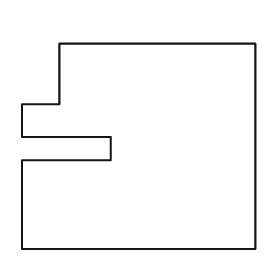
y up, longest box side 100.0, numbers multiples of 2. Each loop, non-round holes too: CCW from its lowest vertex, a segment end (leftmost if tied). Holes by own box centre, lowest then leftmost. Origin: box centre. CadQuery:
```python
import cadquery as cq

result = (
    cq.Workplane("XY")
    .moveTo(-50.0, -44.0)
    .lineTo(50.0, -44.0)
    .lineTo(50.0, 44.0)
    .lineTo(-34.0, 44.0)
    .lineTo(-34.0, 18.0)
    .lineTo(-50.0, 18.0)
    .lineTo(-50.0, 4.0)
    .lineTo(-12.0, 4.0)
    .lineTo(-12.0, -6.0)
    .lineTo(-50.0, -6.0)
    .close()
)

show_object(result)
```